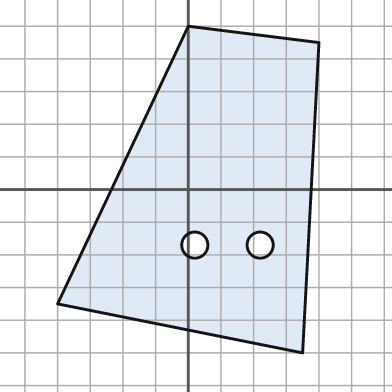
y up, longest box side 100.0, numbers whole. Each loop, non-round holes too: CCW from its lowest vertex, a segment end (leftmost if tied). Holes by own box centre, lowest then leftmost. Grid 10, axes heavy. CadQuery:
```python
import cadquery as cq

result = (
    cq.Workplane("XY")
    .moveTo(35.0, -50.0)
    .lineTo(40.0, 45.0)
    .lineTo(0.0, 50.0)
    .lineTo(-40.0, -35.0)
    .close()
    .moveTo(2.0, -17.0)
    .circle(4.0)
    .moveTo(22.0, -17.0)
    .circle(4.0)
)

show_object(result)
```